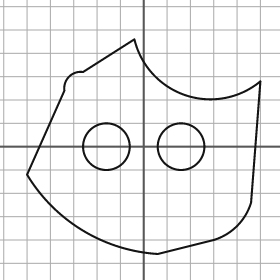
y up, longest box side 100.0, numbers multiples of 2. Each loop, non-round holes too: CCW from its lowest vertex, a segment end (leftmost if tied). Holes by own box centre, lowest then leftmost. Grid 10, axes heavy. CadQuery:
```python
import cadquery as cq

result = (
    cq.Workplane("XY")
    .moveTo(6.0, -46.0)
    .lineTo(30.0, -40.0)
    .threePointArc((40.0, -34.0), (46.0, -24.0))
    .lineTo(50.0, 28.0)
    .threePointArc((18.0, 22.0), (-4.0, 46.0))
    .lineTo(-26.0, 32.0)
    .threePointArc((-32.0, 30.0), (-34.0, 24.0))
    .lineTo(-50.0, -12.0)
    .threePointArc((-26.0, -36.0), (6.0, -46.0))
    .close()
    .moveTo(-16.0, 0.0)
    .circle(10.0)
    .moveTo(16.0, 0.0)
    .circle(10.0)
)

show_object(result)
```